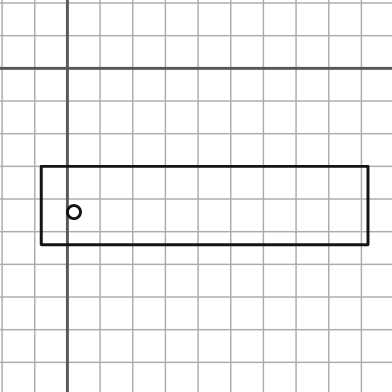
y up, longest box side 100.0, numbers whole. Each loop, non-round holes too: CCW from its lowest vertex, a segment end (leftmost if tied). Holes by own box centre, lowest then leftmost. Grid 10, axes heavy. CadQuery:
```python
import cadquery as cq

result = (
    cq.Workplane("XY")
    .moveTo(-8.0, -54.0)
    .lineTo(92.0, -54.0)
    .lineTo(92.0, -30.0)
    .lineTo(-8.0, -30.0)
    .close()
    .moveTo(2.0, -44.0)
    .circle(2.0)
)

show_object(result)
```